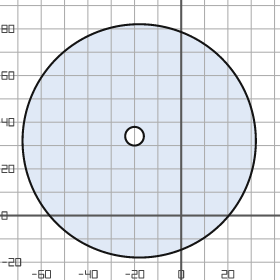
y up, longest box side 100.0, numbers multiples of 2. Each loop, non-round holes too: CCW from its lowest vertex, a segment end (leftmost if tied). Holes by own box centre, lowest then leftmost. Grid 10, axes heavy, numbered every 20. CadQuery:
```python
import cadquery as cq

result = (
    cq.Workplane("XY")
    .moveTo(-18.0, 32.0)
    .circle(50.0)
    .moveTo(-20.0, 34.0)
    .circle(4.0)
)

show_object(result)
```